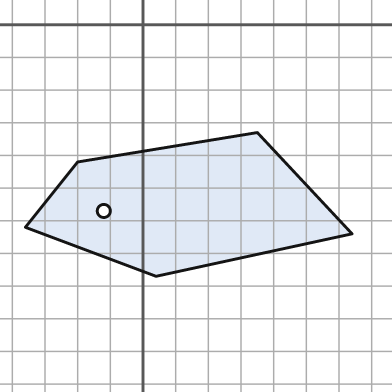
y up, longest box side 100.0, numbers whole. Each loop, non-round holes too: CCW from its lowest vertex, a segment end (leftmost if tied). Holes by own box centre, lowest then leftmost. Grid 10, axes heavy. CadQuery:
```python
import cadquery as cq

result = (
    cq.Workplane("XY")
    .moveTo(4.0, -77.0)
    .lineTo(64.0, -64.0)
    .lineTo(35.0, -33.0)
    .lineTo(-20.0, -42.0)
    .lineTo(-36.0, -62.0)
    .close()
    .moveTo(-12.0, -57.0)
    .circle(2.0)
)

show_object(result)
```